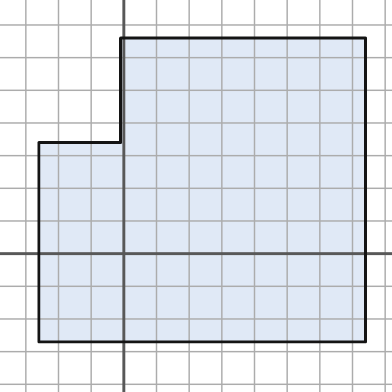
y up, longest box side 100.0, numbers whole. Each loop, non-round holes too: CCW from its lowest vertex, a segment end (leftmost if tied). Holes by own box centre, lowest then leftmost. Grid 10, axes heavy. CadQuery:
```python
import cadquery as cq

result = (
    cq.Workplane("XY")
    .moveTo(-26.0, -27.0)
    .lineTo(74.0, -27.0)
    .lineTo(74.0, 66.0)
    .lineTo(-1.0, 66.0)
    .lineTo(-1.0, 34.0)
    .lineTo(-26.0, 34.0)
    .close()
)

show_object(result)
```